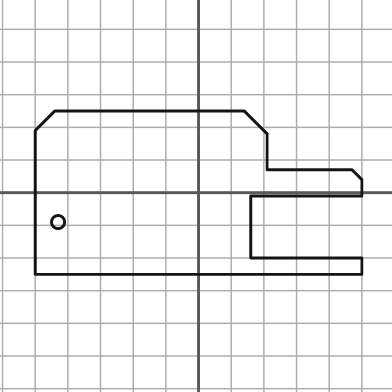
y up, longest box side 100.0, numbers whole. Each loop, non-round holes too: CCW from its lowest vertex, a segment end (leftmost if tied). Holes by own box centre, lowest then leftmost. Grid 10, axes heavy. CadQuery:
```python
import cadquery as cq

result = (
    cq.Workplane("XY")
    .moveTo(-50.0, -25.0)
    .lineTo(50.0, -25.0)
    .lineTo(50.0, -20.0)
    .lineTo(16.0, -20.0)
    .lineTo(16.0, -1.0)
    .lineTo(50.0, -1.0)
    .lineTo(50.0, 4.0)
    .lineTo(47.0, 7.0)
    .lineTo(21.0, 7.0)
    .lineTo(21.0, 18.0)
    .lineTo(14.0, 25.0)
    .lineTo(-44.0, 25.0)
    .lineTo(-50.0, 19.0)
    .close()
    .moveTo(-43.0, -9.0)
    .circle(2.0)
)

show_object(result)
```